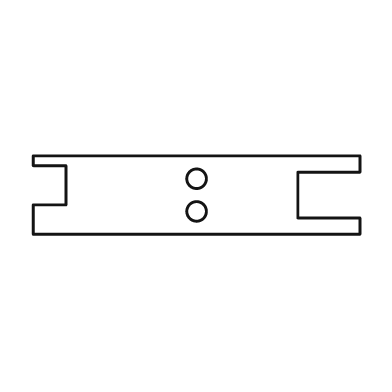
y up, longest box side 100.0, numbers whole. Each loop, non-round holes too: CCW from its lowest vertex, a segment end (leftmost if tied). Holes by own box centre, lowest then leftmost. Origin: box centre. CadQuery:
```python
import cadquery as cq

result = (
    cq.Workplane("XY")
    .moveTo(-50.0, -12.0)
    .lineTo(50.0, -12.0)
    .lineTo(50.0, -7.0)
    .lineTo(31.0, -7.0)
    .lineTo(31.0, 7.0)
    .lineTo(50.0, 7.0)
    .lineTo(50.0, 12.0)
    .lineTo(-50.0, 12.0)
    .lineTo(-50.0, 9.0)
    .lineTo(-40.0, 9.0)
    .lineTo(-40.0, -3.0)
    .lineTo(-50.0, -3.0)
    .close()
    .moveTo(0.0, -5.0)
    .circle(3.0)
    .moveTo(0.0, 5.0)
    .circle(3.0)
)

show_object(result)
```